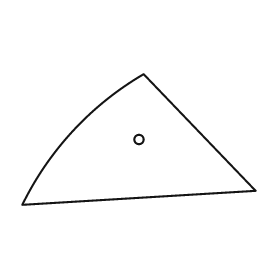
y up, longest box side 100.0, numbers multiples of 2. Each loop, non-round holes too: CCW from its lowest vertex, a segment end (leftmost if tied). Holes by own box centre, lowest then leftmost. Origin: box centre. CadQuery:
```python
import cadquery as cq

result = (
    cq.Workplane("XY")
    .moveTo(-50.0, -28.0)
    .lineTo(50.0, -22.0)
    .lineTo(2.0, 28.0)
    .threePointArc((-28.0, 4.0), (-50.0, -28.0))
    .close()
    .moveTo(0.0, 0.0)
    .circle(2.0)
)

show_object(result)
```